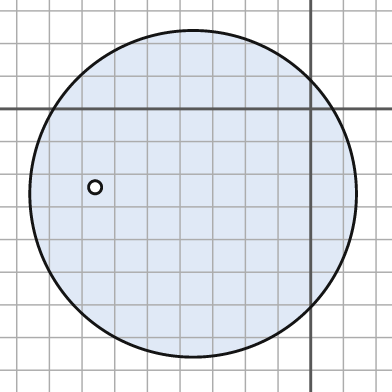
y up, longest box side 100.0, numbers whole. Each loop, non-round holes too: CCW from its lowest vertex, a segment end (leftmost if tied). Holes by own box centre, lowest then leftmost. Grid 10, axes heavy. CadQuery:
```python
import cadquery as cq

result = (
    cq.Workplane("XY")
    .moveTo(-36.0, -26.0)
    .circle(50.0)
    .moveTo(-66.0, -24.0)
    .circle(2.0)
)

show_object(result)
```